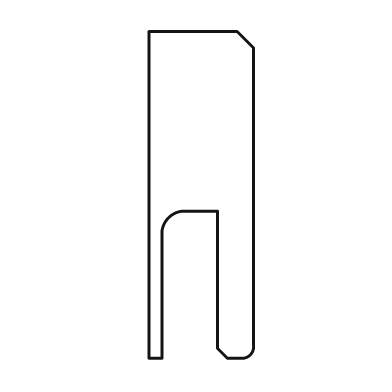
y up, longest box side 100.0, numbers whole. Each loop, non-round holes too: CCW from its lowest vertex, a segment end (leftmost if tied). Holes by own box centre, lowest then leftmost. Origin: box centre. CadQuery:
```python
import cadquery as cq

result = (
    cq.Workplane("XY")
    .moveTo(-16.0, -50.0)
    .lineTo(-12.0, -50.0)
    .lineTo(-12.0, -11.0)
    .threePointArc((-10.0, -7.0), (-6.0, -5.0))
    .lineTo(5.0, -5.0)
    .lineTo(5.0, -47.0)
    .lineTo(8.0, -50.0)
    .lineTo(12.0, -50.0)
    .threePointArc((15.0, -49.0), (16.0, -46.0))
    .lineTo(16.0, 45.0)
    .lineTo(11.0, 50.0)
    .lineTo(-16.0, 50.0)
    .close()
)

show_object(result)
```